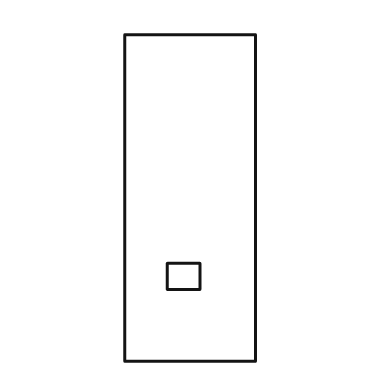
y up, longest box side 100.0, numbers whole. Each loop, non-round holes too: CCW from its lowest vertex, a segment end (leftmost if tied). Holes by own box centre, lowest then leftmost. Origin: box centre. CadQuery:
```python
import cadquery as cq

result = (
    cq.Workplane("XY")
    .moveTo(-20.0, -50.0)
    .lineTo(20.0, -50.0)
    .lineTo(20.0, 50.0)
    .lineTo(-20.0, 50.0)
    .close()
    .moveTo(-7.0, -28.0)
    .lineTo(3.0, -28.0)
    .lineTo(3.0, -20.0)
    .lineTo(-7.0, -20.0)
    .close()
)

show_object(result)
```